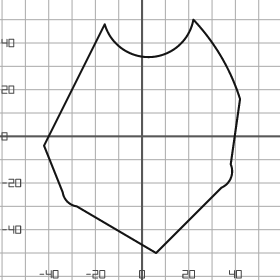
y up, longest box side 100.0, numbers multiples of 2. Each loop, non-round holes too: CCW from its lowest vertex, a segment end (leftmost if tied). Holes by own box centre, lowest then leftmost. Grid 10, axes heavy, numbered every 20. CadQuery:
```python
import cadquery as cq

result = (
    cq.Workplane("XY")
    .moveTo(6.0, -50.0)
    .lineTo(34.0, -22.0)
    .threePointArc((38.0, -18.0), (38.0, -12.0))
    .lineTo(42.0, 16.0)
    .threePointArc((34.0, 34.0), (22.0, 50.0))
    .threePointArc((4.0, 34.0), (-16.0, 48.0))
    .lineTo(-42.0, -4.0)
    .lineTo(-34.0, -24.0)
    .threePointArc((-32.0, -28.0), (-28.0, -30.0))
    .close()
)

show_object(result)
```